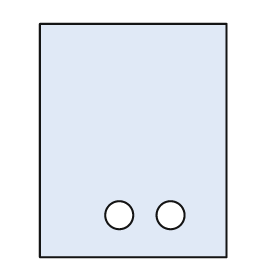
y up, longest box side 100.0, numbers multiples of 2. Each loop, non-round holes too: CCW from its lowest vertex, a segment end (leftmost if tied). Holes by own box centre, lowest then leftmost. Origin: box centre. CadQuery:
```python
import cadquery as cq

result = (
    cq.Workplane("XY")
    .moveTo(-40.0, -50.0)
    .lineTo(40.0, -50.0)
    .lineTo(40.0, 50.0)
    .lineTo(-40.0, 50.0)
    .close()
    .moveTo(-6.0, -32.0)
    .circle(6.0)
    .moveTo(16.0, -32.0)
    .circle(6.0)
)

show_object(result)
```